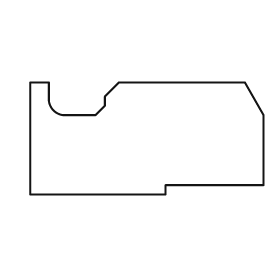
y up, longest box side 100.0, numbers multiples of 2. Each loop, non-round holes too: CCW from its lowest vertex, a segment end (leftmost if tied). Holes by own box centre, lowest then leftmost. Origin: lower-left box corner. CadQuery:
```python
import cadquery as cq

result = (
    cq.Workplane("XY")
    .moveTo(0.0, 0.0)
    .lineTo(58.0, 0.0)
    .lineTo(58.0, 4.0)
    .lineTo(100.0, 4.0)
    .lineTo(100.0, 34.0)
    .lineTo(92.0, 48.0)
    .lineTo(38.0, 48.0)
    .lineTo(32.0, 42.0)
    .lineTo(32.0, 38.0)
    .lineTo(28.0, 34.0)
    .lineTo(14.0, 34.0)
    .threePointArc((10.0, 36.0), (8.0, 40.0))
    .lineTo(8.0, 48.0)
    .lineTo(0.0, 48.0)
    .close()
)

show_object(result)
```